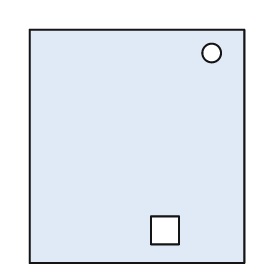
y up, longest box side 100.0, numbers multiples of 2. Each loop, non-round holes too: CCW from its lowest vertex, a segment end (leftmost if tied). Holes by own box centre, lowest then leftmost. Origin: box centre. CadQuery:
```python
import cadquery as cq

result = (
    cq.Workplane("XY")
    .moveTo(-46.0, -50.0)
    .lineTo(46.0, -50.0)
    .lineTo(46.0, 50.0)
    .lineTo(-46.0, 50.0)
    .close()
    .moveTo(6.0, -42.0)
    .lineTo(18.0, -42.0)
    .lineTo(18.0, -30.0)
    .lineTo(6.0, -30.0)
    .close()
    .moveTo(32.0, 40.0)
    .circle(4.0)
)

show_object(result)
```